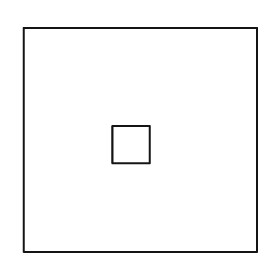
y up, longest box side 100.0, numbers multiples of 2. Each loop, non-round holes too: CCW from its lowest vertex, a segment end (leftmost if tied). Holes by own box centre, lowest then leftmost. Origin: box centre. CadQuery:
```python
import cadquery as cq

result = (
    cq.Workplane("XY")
    .moveTo(-50.0, -48.0)
    .lineTo(50.0, -48.0)
    .lineTo(50.0, 48.0)
    .lineTo(-50.0, 48.0)
    .close()
    .moveTo(-12.0, -10.0)
    .lineTo(4.0, -10.0)
    .lineTo(4.0, 6.0)
    .lineTo(-12.0, 6.0)
    .close()
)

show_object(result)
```